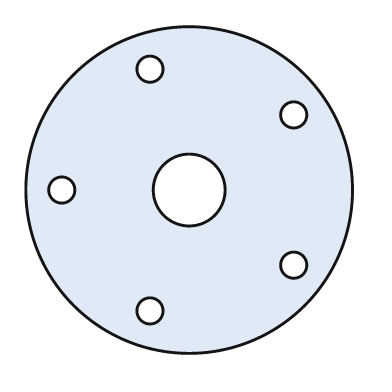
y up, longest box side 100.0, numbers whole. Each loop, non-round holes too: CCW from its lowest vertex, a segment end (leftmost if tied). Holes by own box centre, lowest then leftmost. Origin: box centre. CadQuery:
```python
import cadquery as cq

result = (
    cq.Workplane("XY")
    .moveTo(0.0, 0.0)
    .circle(50.0)
    .moveTo(-12.0, -37.0)
    .circle(4.0)
    .moveTo(32.0, -23.0)
    .circle(4.0)
    .moveTo(-39.0, 0.0)
    .circle(4.0)
    .moveTo(0.0, 0.0)
    .circle(11.0)
    .moveTo(32.0, 23.0)
    .circle(4.0)
    .moveTo(-12.0, 37.0)
    .circle(4.0)
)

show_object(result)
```